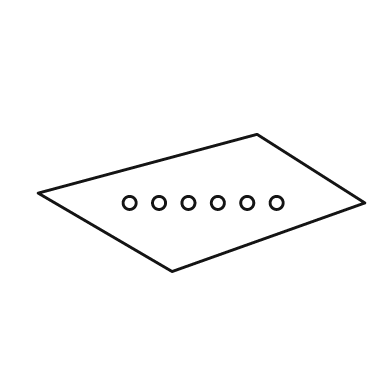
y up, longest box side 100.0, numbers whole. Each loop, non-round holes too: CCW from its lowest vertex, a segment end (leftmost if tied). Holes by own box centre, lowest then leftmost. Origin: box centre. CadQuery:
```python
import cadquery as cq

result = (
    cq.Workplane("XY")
    .moveTo(-9.0, -21.0)
    .lineTo(50.0, 0.0)
    .lineTo(17.0, 21.0)
    .lineTo(-50.0, 3.0)
    .close()
    .moveTo(-22.0, 0.0)
    .circle(2.0)
    .moveTo(-13.0, 0.0)
    .circle(2.0)
    .moveTo(-4.0, 0.0)
    .circle(2.0)
    .moveTo(5.0, 0.0)
    .circle(2.0)
    .moveTo(14.0, 0.0)
    .circle(2.0)
    .moveTo(23.0, 0.0)
    .circle(2.0)
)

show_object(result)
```